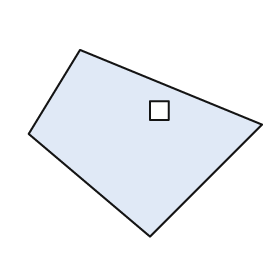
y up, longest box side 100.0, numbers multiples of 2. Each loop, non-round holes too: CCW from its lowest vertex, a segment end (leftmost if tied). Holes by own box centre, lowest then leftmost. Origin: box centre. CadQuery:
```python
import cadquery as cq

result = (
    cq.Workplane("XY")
    .moveTo(2.0, -40.0)
    .lineTo(50.0, 8.0)
    .lineTo(-28.0, 40.0)
    .lineTo(-50.0, 4.0)
    .close()
    .moveTo(2.0, 10.0)
    .lineTo(10.0, 10.0)
    .lineTo(10.0, 18.0)
    .lineTo(2.0, 18.0)
    .close()
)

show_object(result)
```